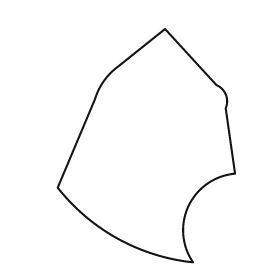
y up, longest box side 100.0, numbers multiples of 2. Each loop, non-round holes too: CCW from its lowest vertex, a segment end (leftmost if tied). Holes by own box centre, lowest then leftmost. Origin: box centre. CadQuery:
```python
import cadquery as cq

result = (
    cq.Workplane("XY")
    .moveTo(20.0, -50.0)
    .threePointArc((18.0, -26.0), (38.0, -12.0))
    .lineTo(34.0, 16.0)
    .threePointArc((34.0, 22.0), (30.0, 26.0))
    .lineTo(8.0, 50.0)
    .lineTo(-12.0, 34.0)
    .threePointArc((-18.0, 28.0), (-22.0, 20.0))
    .lineTo(-38.0, -18.0)
    .threePointArc((-12.0, -40.0), (20.0, -50.0))
    .close()
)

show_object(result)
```